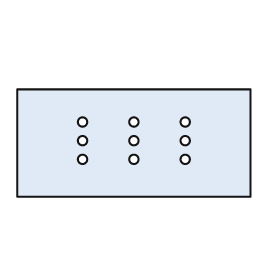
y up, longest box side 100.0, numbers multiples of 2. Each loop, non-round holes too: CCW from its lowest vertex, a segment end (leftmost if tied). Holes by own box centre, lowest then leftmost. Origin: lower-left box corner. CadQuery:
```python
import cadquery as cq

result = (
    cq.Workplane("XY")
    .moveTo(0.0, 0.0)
    .lineTo(100.0, 0.0)
    .lineTo(100.0, 46.0)
    .lineTo(0.0, 46.0)
    .close()
    .moveTo(28.0, 16.0)
    .circle(2.0)
    .moveTo(50.0, 16.0)
    .circle(2.0)
    .moveTo(72.0, 16.0)
    .circle(2.0)
    .moveTo(28.0, 24.0)
    .circle(2.0)
    .moveTo(50.0, 24.0)
    .circle(2.0)
    .moveTo(72.0, 24.0)
    .circle(2.0)
    .moveTo(28.0, 32.0)
    .circle(2.0)
    .moveTo(50.0, 32.0)
    .circle(2.0)
    .moveTo(72.0, 32.0)
    .circle(2.0)
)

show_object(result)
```